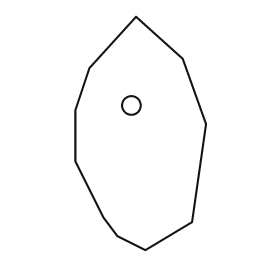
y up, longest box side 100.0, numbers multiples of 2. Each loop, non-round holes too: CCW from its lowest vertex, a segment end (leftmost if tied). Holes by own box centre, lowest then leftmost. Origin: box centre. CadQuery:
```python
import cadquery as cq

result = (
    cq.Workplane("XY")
    .moveTo(2.0, -50.0)
    .lineTo(22.0, -38.0)
    .lineTo(28.0, 4.0)
    .lineTo(18.0, 32.0)
    .lineTo(-2.0, 50.0)
    .lineTo(-22.0, 28.0)
    .lineTo(-28.0, 10.0)
    .lineTo(-28.0, -12.0)
    .lineTo(-16.0, -36.0)
    .lineTo(-10.0, -44.0)
    .close()
    .moveTo(-4.0, 12.0)
    .circle(4.0)
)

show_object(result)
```